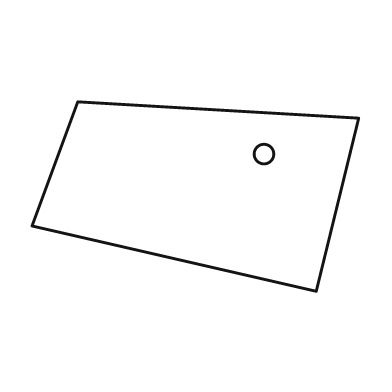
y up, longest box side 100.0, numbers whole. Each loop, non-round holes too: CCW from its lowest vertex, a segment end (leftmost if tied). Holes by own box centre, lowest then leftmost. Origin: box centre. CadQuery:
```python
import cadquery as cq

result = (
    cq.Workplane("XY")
    .moveTo(37.0, -29.0)
    .lineTo(50.0, 24.0)
    .lineTo(-36.0, 29.0)
    .lineTo(-50.0, -9.0)
    .close()
    .moveTo(21.0, 13.0)
    .circle(3.0)
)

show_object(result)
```